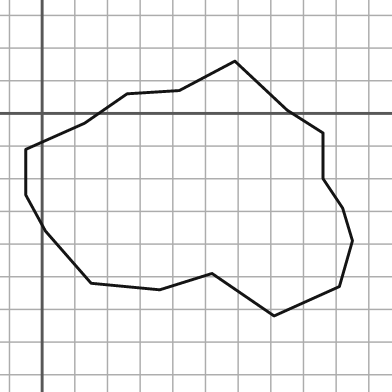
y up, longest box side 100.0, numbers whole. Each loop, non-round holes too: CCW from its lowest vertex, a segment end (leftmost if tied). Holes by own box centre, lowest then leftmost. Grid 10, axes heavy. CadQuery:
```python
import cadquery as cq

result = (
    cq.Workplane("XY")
    .moveTo(71.0, -62.0)
    .lineTo(91.0, -53.0)
    .lineTo(95.0, -39.0)
    .lineTo(92.0, -29.0)
    .lineTo(86.0, -20.0)
    .lineTo(86.0, -6.0)
    .lineTo(75.0, 1.0)
    .lineTo(59.0, 16.0)
    .lineTo(42.0, 7.0)
    .lineTo(26.0, 6.0)
    .lineTo(13.0, -3.0)
    .lineTo(-5.0, -11.0)
    .lineTo(-5.0, -25.0)
    .lineTo(1.0, -36.0)
    .lineTo(15.0, -52.0)
    .lineTo(36.0, -54.0)
    .lineTo(52.0, -49.0)
    .close()
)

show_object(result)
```